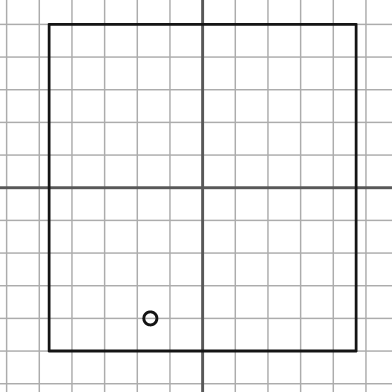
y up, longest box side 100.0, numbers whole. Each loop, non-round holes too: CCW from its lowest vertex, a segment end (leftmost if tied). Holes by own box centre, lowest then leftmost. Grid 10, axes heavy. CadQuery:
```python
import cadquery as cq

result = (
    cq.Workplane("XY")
    .moveTo(-47.0, -50.0)
    .lineTo(47.0, -50.0)
    .lineTo(47.0, 50.0)
    .lineTo(-47.0, 50.0)
    .close()
    .moveTo(-16.0, -40.0)
    .circle(2.0)
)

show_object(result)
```